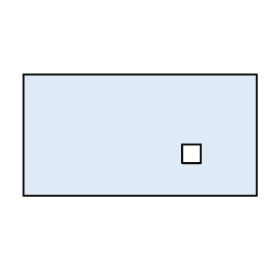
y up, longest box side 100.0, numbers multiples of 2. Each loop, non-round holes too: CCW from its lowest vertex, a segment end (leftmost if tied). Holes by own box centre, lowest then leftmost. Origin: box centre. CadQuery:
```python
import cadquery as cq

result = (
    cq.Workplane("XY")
    .moveTo(-50.0, -26.0)
    .lineTo(50.0, -26.0)
    .lineTo(50.0, 26.0)
    .lineTo(-50.0, 26.0)
    .close()
    .moveTo(18.0, -12.0)
    .lineTo(26.0, -12.0)
    .lineTo(26.0, -4.0)
    .lineTo(18.0, -4.0)
    .close()
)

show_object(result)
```